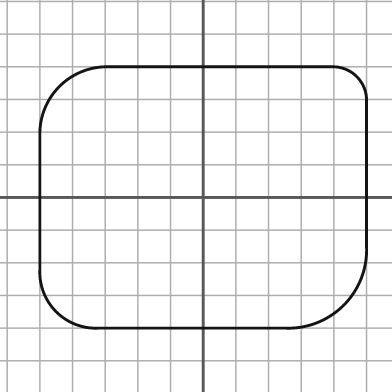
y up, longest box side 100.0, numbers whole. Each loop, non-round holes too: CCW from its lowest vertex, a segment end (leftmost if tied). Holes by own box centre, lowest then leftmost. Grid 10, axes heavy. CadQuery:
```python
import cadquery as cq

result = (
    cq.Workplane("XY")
    .moveTo(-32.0, -40.0)
    .lineTo(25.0, -40.0)
    .threePointArc((43.0, -33.0), (50.0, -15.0))
    .lineTo(50.0, 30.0)
    .threePointArc((47.0, 37.0), (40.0, 40.0))
    .lineTo(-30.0, 40.0)
    .threePointArc((-44.0, 34.0), (-50.0, 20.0))
    .lineTo(-50.0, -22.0)
    .threePointArc((-45.0, -35.0), (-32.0, -40.0))
    .close()
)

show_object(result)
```